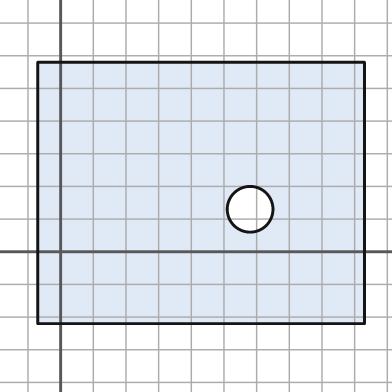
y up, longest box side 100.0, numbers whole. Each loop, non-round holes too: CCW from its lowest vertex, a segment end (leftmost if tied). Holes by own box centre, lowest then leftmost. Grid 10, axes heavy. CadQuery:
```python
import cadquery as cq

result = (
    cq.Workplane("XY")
    .moveTo(-7.0, -22.0)
    .lineTo(93.0, -22.0)
    .lineTo(93.0, 58.0)
    .lineTo(-7.0, 58.0)
    .close()
    .moveTo(58.0, 13.0)
    .circle(7.0)
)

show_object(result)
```